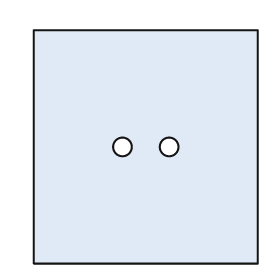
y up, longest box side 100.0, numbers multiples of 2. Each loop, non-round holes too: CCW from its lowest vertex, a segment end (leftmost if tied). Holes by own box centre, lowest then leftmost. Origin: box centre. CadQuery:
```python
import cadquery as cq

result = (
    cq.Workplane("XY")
    .moveTo(-48.0, -50.0)
    .lineTo(48.0, -50.0)
    .lineTo(48.0, 50.0)
    .lineTo(-48.0, 50.0)
    .close()
    .moveTo(-10.0, 0.0)
    .circle(4.0)
    .moveTo(10.0, 0.0)
    .circle(4.0)
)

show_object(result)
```